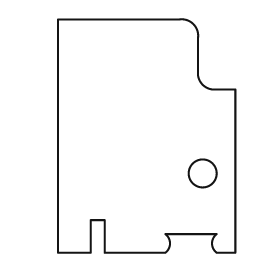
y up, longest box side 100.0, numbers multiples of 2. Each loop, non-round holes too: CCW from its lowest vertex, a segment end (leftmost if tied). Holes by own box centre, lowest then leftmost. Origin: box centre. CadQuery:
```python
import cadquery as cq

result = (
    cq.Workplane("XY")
    .moveTo(-38.0, -50.0)
    .lineTo(-24.0, -50.0)
    .lineTo(-24.0, -36.0)
    .lineTo(-18.0, -36.0)
    .lineTo(-18.0, -50.0)
    .lineTo(8.0, -50.0)
    .threePointArc((10.0, -46.0), (8.0, -42.0))
    .lineTo(30.0, -42.0)
    .threePointArc((28.0, -46.0), (30.0, -50.0))
    .lineTo(38.0, -50.0)
    .lineTo(38.0, 20.0)
    .lineTo(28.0, 20.0)
    .threePointArc((24.0, 22.0), (22.0, 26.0))
    .lineTo(22.0, 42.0)
    .threePointArc((20.0, 48.0), (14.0, 50.0))
    .lineTo(-38.0, 50.0)
    .close()
    .moveTo(24.0, -16.0)
    .circle(6.0)
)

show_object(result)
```